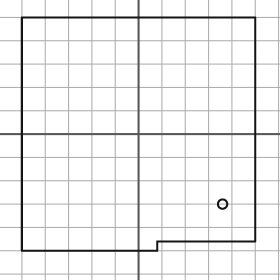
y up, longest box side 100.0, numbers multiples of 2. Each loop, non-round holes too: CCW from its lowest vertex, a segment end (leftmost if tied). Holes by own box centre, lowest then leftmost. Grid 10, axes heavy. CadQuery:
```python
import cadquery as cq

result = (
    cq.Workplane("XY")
    .moveTo(-50.0, -50.0)
    .lineTo(8.0, -50.0)
    .lineTo(8.0, -46.0)
    .lineTo(50.0, -46.0)
    .lineTo(50.0, 50.0)
    .lineTo(-50.0, 50.0)
    .close()
    .moveTo(36.0, -30.0)
    .circle(2.0)
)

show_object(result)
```